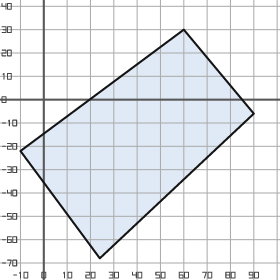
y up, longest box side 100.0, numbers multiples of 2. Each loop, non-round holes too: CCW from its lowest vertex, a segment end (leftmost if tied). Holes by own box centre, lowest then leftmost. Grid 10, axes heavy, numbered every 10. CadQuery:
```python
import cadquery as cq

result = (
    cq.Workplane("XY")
    .moveTo(24.0, -68.0)
    .lineTo(90.0, -6.0)
    .lineTo(60.0, 30.0)
    .lineTo(-10.0, -22.0)
    .close()
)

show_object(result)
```